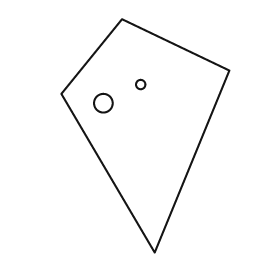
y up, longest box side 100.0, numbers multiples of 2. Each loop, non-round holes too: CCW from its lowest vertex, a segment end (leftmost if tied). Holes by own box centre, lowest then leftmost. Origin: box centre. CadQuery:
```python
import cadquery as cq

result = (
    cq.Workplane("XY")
    .moveTo(4.0, -50.0)
    .lineTo(36.0, 28.0)
    .lineTo(-10.0, 50.0)
    .lineTo(-36.0, 18.0)
    .close()
    .moveTo(-18.0, 14.0)
    .circle(4.0)
    .moveTo(-2.0, 22.0)
    .circle(2.0)
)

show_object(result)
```